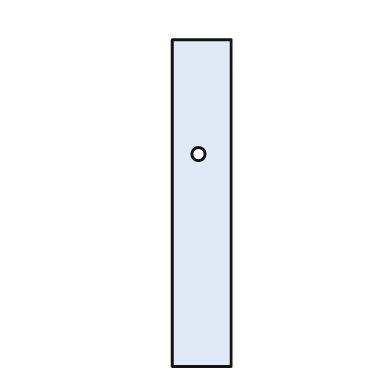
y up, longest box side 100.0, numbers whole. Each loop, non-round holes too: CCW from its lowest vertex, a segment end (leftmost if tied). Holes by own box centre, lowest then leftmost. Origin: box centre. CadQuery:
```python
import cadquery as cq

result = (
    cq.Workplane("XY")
    .moveTo(-9.0, -50.0)
    .lineTo(9.0, -50.0)
    .lineTo(9.0, 50.0)
    .lineTo(-9.0, 50.0)
    .close()
    .moveTo(-1.0, 15.0)
    .circle(2.0)
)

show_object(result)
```